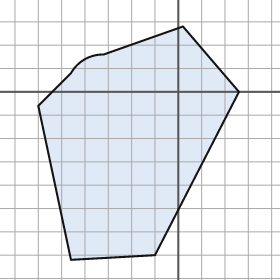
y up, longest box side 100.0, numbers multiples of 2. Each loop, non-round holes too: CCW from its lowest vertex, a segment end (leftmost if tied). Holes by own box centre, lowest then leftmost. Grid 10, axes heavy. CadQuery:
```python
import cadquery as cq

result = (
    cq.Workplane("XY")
    .moveTo(-46.0, -72.0)
    .lineTo(-10.0, -70.0)
    .lineTo(26.0, 0.0)
    .lineTo(2.0, 28.0)
    .lineTo(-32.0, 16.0)
    .threePointArc((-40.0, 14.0), (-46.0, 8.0))
    .lineTo(-60.0, -6.0)
    .close()
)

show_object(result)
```